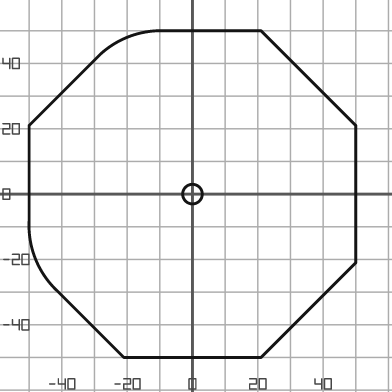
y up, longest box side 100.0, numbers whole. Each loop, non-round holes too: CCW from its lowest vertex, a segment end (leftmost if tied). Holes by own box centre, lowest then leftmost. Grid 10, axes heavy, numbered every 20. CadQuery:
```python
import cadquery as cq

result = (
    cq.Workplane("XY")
    .moveTo(-21.0, -50.0)
    .lineTo(21.0, -50.0)
    .lineTo(50.0, -21.0)
    .lineTo(50.0, 21.0)
    .lineTo(21.0, 50.0)
    .lineTo(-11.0, 50.0)
    .threePointArc((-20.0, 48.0), (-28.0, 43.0))
    .lineTo(-50.0, 21.0)
    .lineTo(-50.0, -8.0)
    .threePointArc((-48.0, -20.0), (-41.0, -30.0))
    .close()
    .moveTo(0.0, 0.0)
    .circle(3.0)
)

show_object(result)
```